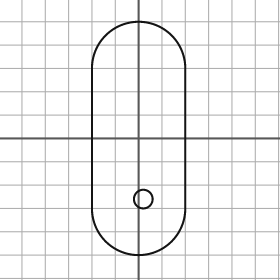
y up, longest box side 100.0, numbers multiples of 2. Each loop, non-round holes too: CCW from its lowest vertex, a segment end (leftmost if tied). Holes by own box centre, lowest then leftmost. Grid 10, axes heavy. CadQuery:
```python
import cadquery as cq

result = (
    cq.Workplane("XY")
    .moveTo(-20.0, -30.0)
    .threePointArc((0.0, -50.0), (20.0, -30.0))
    .lineTo(20.0, 30.0)
    .threePointArc((0.0, 50.0), (-20.0, 30.0))
    .close()
    .moveTo(2.0, -26.0)
    .circle(4.0)
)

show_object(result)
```